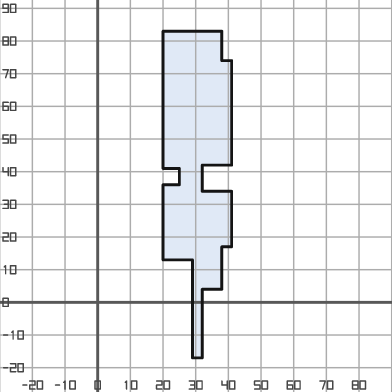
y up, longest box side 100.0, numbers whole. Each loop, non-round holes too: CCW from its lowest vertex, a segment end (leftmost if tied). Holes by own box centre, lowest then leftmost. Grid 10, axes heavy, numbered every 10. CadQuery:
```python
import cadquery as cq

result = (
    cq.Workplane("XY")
    .moveTo(29.0, -17.0)
    .lineTo(32.0, -17.0)
    .lineTo(32.0, 4.0)
    .lineTo(38.0, 4.0)
    .lineTo(38.0, 17.0)
    .lineTo(41.0, 17.0)
    .lineTo(41.0, 34.0)
    .lineTo(32.0, 34.0)
    .lineTo(32.0, 42.0)
    .lineTo(41.0, 42.0)
    .lineTo(41.0, 74.0)
    .lineTo(38.0, 74.0)
    .lineTo(38.0, 83.0)
    .lineTo(20.0, 83.0)
    .lineTo(20.0, 41.0)
    .lineTo(25.0, 41.0)
    .lineTo(25.0, 36.0)
    .lineTo(20.0, 36.0)
    .lineTo(20.0, 13.0)
    .lineTo(29.0, 13.0)
    .close()
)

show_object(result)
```